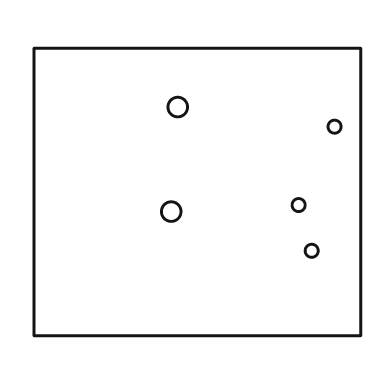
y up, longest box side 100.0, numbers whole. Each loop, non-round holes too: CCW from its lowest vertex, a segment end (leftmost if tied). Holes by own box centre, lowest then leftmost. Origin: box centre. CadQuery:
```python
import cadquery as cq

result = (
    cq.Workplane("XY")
    .moveTo(-50.0, -44.0)
    .lineTo(50.0, -44.0)
    .lineTo(50.0, 44.0)
    .lineTo(-50.0, 44.0)
    .close()
    .moveTo(35.0, -18.0)
    .circle(2.0)
    .moveTo(-8.0, -6.0)
    .circle(3.0)
    .moveTo(31.0, -4.0)
    .circle(2.0)
    .moveTo(42.0, 20.0)
    .circle(2.0)
    .moveTo(-6.0, 26.0)
    .circle(3.0)
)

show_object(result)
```